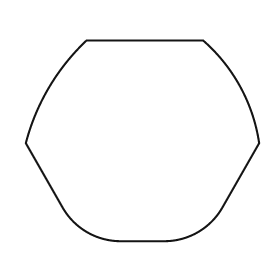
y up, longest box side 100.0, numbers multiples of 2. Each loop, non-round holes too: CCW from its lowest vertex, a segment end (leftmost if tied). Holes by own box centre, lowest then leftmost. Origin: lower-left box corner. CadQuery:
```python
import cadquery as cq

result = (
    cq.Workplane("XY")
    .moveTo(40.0, 0.0)
    .lineTo(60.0, 0.0)
    .threePointArc((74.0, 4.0), (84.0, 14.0))
    .lineTo(100.0, 42.0)
    .threePointArc((92.0, 66.0), (76.0, 86.0))
    .lineTo(26.0, 86.0)
    .threePointArc((10.0, 66.0), (0.0, 42.0))
    .lineTo(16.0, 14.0)
    .threePointArc((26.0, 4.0), (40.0, 0.0))
    .close()
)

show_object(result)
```